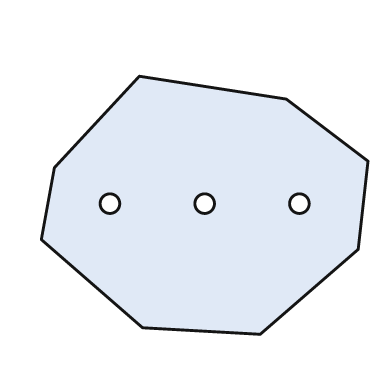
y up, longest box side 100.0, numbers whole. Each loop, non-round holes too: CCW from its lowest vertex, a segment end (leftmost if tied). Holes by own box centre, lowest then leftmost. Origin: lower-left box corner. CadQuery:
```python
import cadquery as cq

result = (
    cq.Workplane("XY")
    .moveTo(67.0, 0.0)
    .lineTo(97.0, 26.0)
    .lineTo(100.0, 53.0)
    .lineTo(75.0, 72.0)
    .lineTo(30.0, 79.0)
    .lineTo(4.0, 51.0)
    .lineTo(0.0, 29.0)
    .lineTo(31.0, 2.0)
    .close()
    .moveTo(21.0, 40.0)
    .circle(3.0)
    .moveTo(50.0, 40.0)
    .circle(3.0)
    .moveTo(79.0, 40.0)
    .circle(3.0)
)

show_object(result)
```